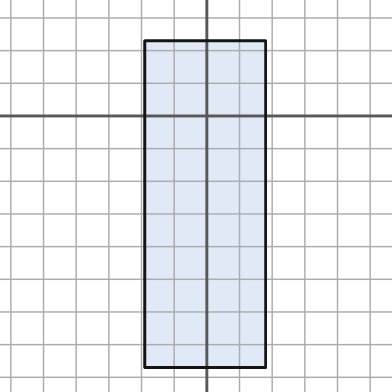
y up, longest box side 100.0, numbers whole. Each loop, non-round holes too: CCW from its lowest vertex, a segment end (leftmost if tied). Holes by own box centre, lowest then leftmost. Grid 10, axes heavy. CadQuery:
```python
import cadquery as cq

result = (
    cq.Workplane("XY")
    .moveTo(-19.0, -77.0)
    .lineTo(18.0, -77.0)
    .lineTo(18.0, 23.0)
    .lineTo(-19.0, 23.0)
    .close()
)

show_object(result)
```